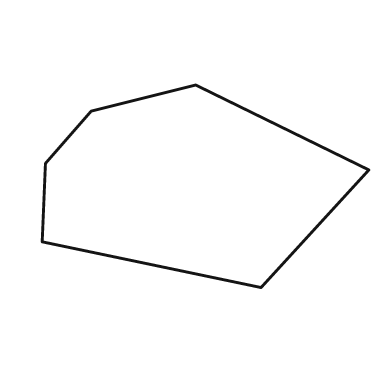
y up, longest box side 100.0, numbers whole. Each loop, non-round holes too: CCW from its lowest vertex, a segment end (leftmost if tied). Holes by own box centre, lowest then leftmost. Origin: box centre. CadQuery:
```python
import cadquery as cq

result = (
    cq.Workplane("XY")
    .moveTo(17.0, -31.0)
    .lineTo(50.0, 5.0)
    .lineTo(-3.0, 31.0)
    .lineTo(-35.0, 23.0)
    .lineTo(-49.0, 7.0)
    .lineTo(-50.0, -17.0)
    .close()
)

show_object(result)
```